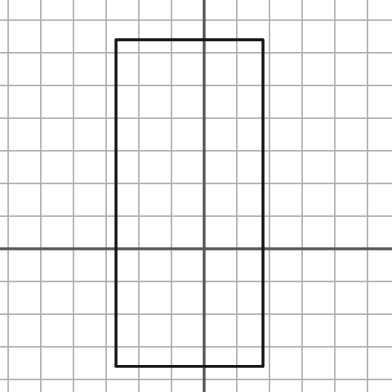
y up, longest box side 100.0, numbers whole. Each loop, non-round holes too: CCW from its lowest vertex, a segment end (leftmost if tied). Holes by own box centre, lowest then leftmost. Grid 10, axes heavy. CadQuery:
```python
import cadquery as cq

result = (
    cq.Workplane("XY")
    .moveTo(-27.0, -36.0)
    .lineTo(18.0, -36.0)
    .lineTo(18.0, 64.0)
    .lineTo(-27.0, 64.0)
    .close()
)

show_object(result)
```